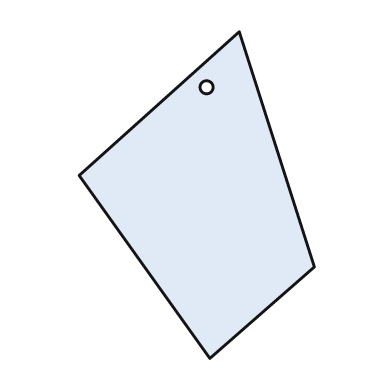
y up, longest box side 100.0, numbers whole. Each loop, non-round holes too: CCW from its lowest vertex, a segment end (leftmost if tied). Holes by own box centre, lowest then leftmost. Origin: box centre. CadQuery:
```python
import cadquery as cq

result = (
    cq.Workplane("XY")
    .moveTo(4.0, -50.0)
    .lineTo(36.0, -22.0)
    .lineTo(13.0, 50.0)
    .lineTo(-36.0, 6.0)
    .close()
    .moveTo(3.0, 33.0)
    .circle(2.0)
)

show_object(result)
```